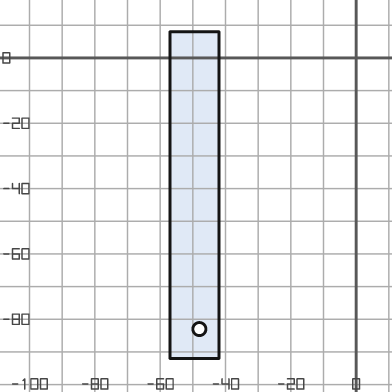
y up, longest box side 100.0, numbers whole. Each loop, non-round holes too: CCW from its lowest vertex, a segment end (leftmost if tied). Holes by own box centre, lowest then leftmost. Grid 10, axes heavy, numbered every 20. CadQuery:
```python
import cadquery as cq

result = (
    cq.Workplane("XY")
    .moveTo(-57.0, -92.0)
    .lineTo(-42.0, -92.0)
    .lineTo(-42.0, 8.0)
    .lineTo(-57.0, 8.0)
    .close()
    .moveTo(-48.0, -83.0)
    .circle(2.0)
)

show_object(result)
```